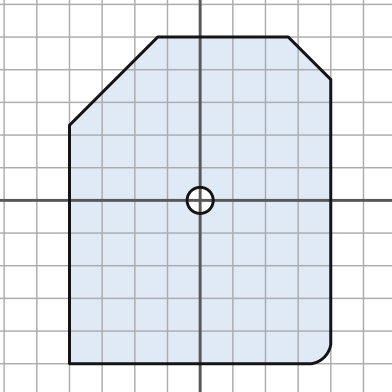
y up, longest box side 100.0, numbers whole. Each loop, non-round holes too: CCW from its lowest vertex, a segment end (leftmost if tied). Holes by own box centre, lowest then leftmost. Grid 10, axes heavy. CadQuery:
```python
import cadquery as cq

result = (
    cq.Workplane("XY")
    .moveTo(-40.0, -50.0)
    .lineTo(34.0, -50.0)
    .threePointArc((38.0, -48.0), (40.0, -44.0))
    .lineTo(40.0, 37.0)
    .lineTo(27.0, 50.0)
    .lineTo(-13.0, 50.0)
    .lineTo(-40.0, 23.0)
    .close()
    .moveTo(0.0, 0.0)
    .circle(4.0)
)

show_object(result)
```